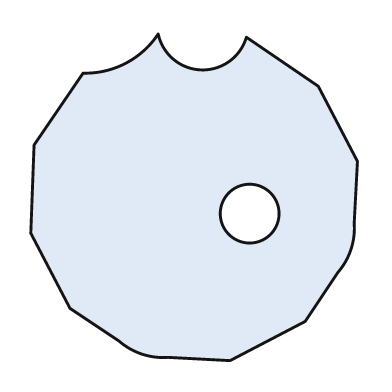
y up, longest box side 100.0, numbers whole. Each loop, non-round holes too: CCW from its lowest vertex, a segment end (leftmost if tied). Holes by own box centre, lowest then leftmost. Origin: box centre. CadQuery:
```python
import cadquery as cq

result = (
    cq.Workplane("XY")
    .moveTo(11.0, -50.0)
    .lineTo(34.0, -38.0)
    .lineTo(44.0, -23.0)
    .threePointArc((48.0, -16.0), (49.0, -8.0))
    .lineTo(50.0, 11.0)
    .lineTo(38.0, 34.0)
    .lineTo(16.0, 49.0)
    .threePointArc((2.0, 39.0), (-11.0, 50.0))
    .threePointArc((-21.0, 41.0), (-34.0, 38.0))
    .lineTo(-49.0, 16.0)
    .lineTo(-50.0, -11.0)
    .lineTo(-38.0, -34.0)
    .lineTo(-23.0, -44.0)
    .threePointArc((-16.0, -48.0), (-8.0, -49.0))
    .close()
    .moveTo(17.0, -5.0)
    .circle(9.0)
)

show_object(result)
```